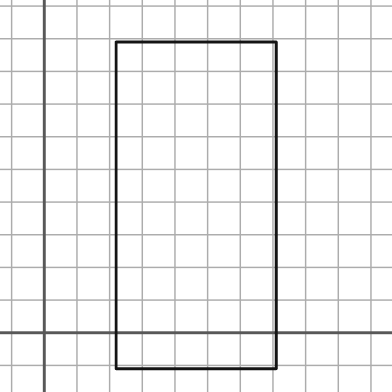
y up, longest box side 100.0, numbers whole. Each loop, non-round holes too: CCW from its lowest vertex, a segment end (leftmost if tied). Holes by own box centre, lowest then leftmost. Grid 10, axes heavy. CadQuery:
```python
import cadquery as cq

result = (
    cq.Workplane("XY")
    .moveTo(22.0, -11.0)
    .lineTo(71.0, -11.0)
    .lineTo(71.0, 89.0)
    .lineTo(22.0, 89.0)
    .close()
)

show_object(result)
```